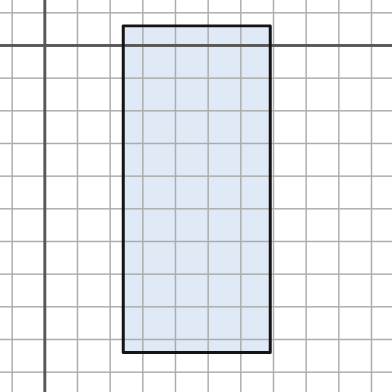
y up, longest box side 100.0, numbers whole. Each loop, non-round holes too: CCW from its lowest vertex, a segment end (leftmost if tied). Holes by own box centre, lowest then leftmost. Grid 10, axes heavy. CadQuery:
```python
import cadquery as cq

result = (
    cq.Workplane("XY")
    .moveTo(24.0, -94.0)
    .lineTo(69.0, -94.0)
    .lineTo(69.0, 6.0)
    .lineTo(24.0, 6.0)
    .close()
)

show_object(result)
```